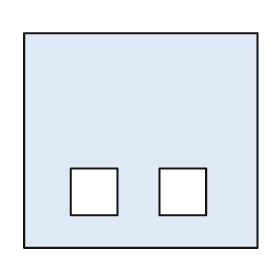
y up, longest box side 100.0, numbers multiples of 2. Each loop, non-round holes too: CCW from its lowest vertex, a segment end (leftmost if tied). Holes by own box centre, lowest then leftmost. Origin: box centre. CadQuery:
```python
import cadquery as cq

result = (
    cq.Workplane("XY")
    .moveTo(-50.0, -46.0)
    .lineTo(50.0, -46.0)
    .lineTo(50.0, 46.0)
    .lineTo(-50.0, 46.0)
    .close()
    .moveTo(-30.0, -32.0)
    .lineTo(-10.0, -32.0)
    .lineTo(-10.0, -12.0)
    .lineTo(-30.0, -12.0)
    .close()
    .moveTo(8.0, -32.0)
    .lineTo(28.0, -32.0)
    .lineTo(28.0, -12.0)
    .lineTo(8.0, -12.0)
    .close()
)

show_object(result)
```